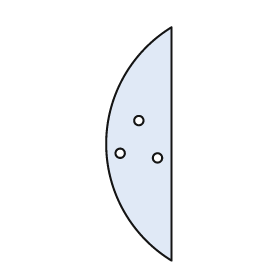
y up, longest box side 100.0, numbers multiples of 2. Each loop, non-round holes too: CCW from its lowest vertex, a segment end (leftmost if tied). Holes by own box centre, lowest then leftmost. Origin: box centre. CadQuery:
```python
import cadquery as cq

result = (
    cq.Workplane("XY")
    .moveTo(14.0, -50.0)
    .lineTo(14.0, 50.0)
    .threePointArc((-14.0, 0.0), (14.0, -50.0))
    .close()
    .moveTo(8.0, -6.0)
    .circle(2.0)
    .moveTo(-8.0, -4.0)
    .circle(2.0)
    .moveTo(0.0, 10.0)
    .circle(2.0)
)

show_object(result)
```